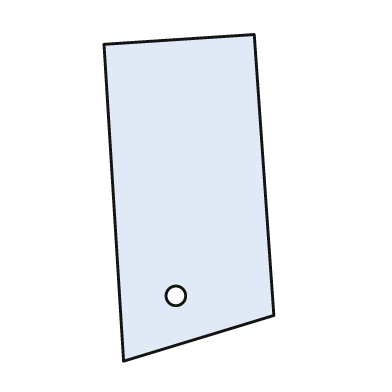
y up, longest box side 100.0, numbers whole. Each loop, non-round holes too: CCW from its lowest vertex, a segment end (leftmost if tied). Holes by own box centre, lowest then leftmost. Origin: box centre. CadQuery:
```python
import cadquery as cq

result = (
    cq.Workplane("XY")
    .moveTo(-20.0, -50.0)
    .lineTo(26.0, -36.0)
    .lineTo(20.0, 50.0)
    .lineTo(-26.0, 47.0)
    .close()
    .moveTo(-4.0, -30.0)
    .circle(3.0)
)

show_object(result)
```